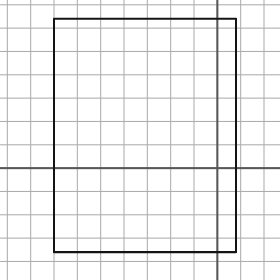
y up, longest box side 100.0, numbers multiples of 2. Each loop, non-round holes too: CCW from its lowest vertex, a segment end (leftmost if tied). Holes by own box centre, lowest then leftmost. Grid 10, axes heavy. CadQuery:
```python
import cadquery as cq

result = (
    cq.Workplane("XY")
    .moveTo(-70.0, -36.0)
    .lineTo(8.0, -36.0)
    .lineTo(8.0, 64.0)
    .lineTo(-70.0, 64.0)
    .close()
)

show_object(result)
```